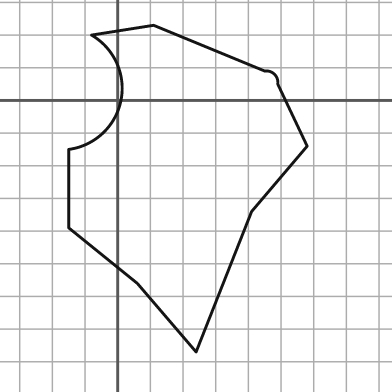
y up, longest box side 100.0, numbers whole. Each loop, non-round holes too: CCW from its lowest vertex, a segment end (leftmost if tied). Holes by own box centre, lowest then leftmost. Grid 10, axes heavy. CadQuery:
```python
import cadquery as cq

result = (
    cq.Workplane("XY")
    .moveTo(24.0, -77.0)
    .lineTo(41.0, -34.0)
    .lineTo(58.0, -14.0)
    .lineTo(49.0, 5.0)
    .threePointArc((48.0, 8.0), (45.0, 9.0))
    .lineTo(11.0, 23.0)
    .lineTo(-8.0, 20.0)
    .threePointArc((1.0, 0.0), (-15.0, -15.0))
    .lineTo(-15.0, -39.0)
    .lineTo(6.0, -56.0)
    .close()
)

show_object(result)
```